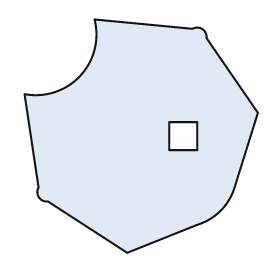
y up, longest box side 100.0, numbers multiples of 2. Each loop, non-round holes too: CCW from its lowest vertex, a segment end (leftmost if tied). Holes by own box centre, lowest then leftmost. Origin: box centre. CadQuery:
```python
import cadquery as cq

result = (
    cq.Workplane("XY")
    .moveTo(-6.0, -50.0)
    .lineTo(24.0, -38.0)
    .threePointArc((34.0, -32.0), (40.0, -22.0))
    .lineTo(50.0, 10.0)
    .lineTo(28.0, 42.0)
    .threePointArc((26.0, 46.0), (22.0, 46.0))
    .lineTo(-20.0, 50.0)
    .threePointArc((-26.0, 26.0), (-50.0, 18.0))
    .lineTo(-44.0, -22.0)
    .threePointArc((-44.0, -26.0), (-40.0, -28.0))
    .close()
    .moveTo(12.0, -6.0)
    .lineTo(24.0, -6.0)
    .lineTo(24.0, 6.0)
    .lineTo(12.0, 6.0)
    .close()
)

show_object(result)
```